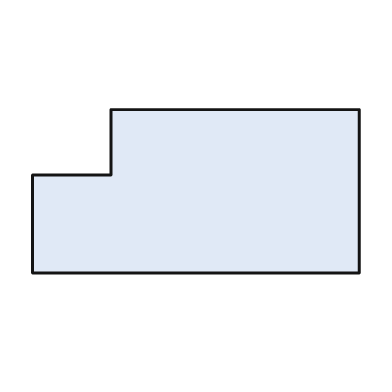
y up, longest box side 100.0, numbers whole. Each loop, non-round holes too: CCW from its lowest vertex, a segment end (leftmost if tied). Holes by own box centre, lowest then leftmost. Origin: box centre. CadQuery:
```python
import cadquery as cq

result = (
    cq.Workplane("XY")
    .moveTo(-50.0, -25.0)
    .lineTo(50.0, -25.0)
    .lineTo(50.0, 25.0)
    .lineTo(-26.0, 25.0)
    .lineTo(-26.0, 5.0)
    .lineTo(-50.0, 5.0)
    .close()
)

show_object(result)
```